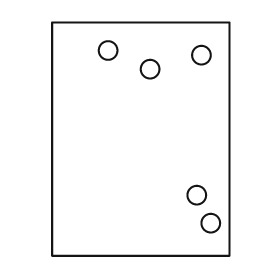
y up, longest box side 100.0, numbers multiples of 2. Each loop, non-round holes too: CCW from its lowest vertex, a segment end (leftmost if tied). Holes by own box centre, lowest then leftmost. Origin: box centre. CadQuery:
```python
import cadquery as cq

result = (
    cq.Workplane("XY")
    .moveTo(-38.0, -50.0)
    .lineTo(38.0, -50.0)
    .lineTo(38.0, 50.0)
    .lineTo(-38.0, 50.0)
    .close()
    .moveTo(30.0, -36.0)
    .circle(4.0)
    .moveTo(24.0, -24.0)
    .circle(4.0)
    .moveTo(4.0, 30.0)
    .circle(4.0)
    .moveTo(26.0, 36.0)
    .circle(4.0)
    .moveTo(-14.0, 38.0)
    .circle(4.0)
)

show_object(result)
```